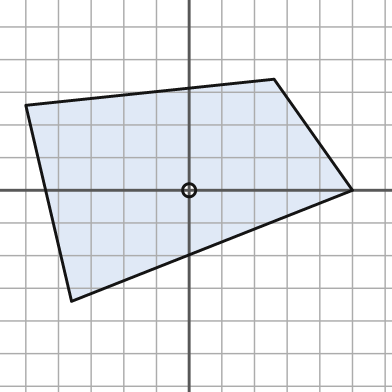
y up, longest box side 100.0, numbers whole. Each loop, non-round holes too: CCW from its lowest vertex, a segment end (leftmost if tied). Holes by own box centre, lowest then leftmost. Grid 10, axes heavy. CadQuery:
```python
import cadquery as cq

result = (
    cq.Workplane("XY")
    .moveTo(-36.0, -34.0)
    .lineTo(50.0, 0.0)
    .lineTo(26.0, 34.0)
    .lineTo(-50.0, 26.0)
    .close()
    .moveTo(0.0, 0.0)
    .circle(2.0)
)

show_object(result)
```